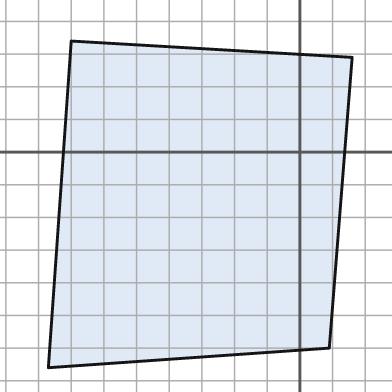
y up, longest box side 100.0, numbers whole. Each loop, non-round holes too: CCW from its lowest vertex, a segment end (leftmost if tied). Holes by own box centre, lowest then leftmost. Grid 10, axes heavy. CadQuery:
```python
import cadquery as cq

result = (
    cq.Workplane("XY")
    .moveTo(-77.0, -66.0)
    .lineTo(9.0, -60.0)
    .lineTo(16.0, 29.0)
    .lineTo(-70.0, 34.0)
    .close()
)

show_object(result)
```